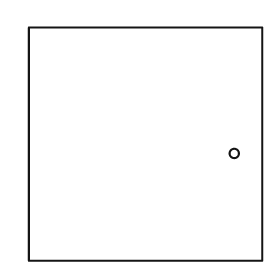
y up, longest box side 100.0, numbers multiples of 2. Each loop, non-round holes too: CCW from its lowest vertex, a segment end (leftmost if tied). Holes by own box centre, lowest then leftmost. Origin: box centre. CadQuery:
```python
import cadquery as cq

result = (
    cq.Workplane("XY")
    .moveTo(-50.0, -50.0)
    .lineTo(50.0, -50.0)
    .lineTo(50.0, 50.0)
    .lineTo(-50.0, 50.0)
    .close()
    .moveTo(38.0, -4.0)
    .circle(2.0)
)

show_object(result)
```